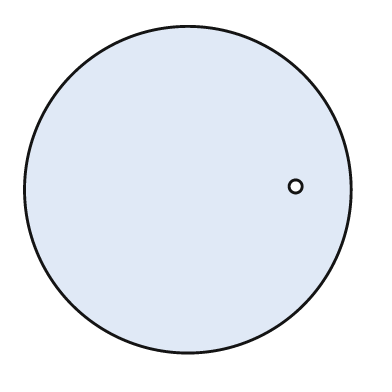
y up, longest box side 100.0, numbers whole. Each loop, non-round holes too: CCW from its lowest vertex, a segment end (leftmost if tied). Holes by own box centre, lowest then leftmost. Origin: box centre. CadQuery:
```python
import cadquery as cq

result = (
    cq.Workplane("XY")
    .moveTo(0.0, 0.0)
    .circle(50.0)
    .moveTo(33.0, 1.0)
    .circle(2.0)
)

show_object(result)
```